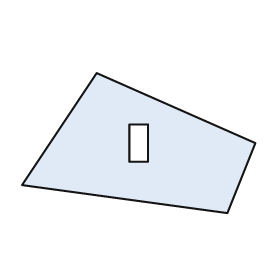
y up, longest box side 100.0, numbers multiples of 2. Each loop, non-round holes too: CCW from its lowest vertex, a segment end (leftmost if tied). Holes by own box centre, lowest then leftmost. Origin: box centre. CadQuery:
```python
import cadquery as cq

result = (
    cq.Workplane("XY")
    .moveTo(38.0, -30.0)
    .lineTo(50.0, 0.0)
    .lineTo(-18.0, 30.0)
    .lineTo(-50.0, -18.0)
    .close()
    .moveTo(-4.0, -8.0)
    .lineTo(4.0, -8.0)
    .lineTo(4.0, 8.0)
    .lineTo(-4.0, 8.0)
    .close()
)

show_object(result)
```